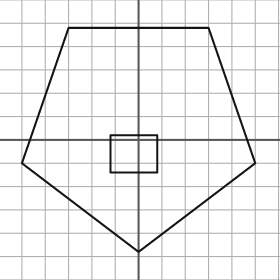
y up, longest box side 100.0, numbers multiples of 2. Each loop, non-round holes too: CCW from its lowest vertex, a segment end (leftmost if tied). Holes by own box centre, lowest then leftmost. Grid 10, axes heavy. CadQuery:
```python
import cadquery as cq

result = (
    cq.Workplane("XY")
    .moveTo(0.0, -48.0)
    .lineTo(50.0, -10.0)
    .lineTo(30.0, 48.0)
    .lineTo(-30.0, 48.0)
    .lineTo(-50.0, -10.0)
    .close()
    .moveTo(-12.0, -14.0)
    .lineTo(8.0, -14.0)
    .lineTo(8.0, 2.0)
    .lineTo(-12.0, 2.0)
    .close()
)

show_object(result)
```